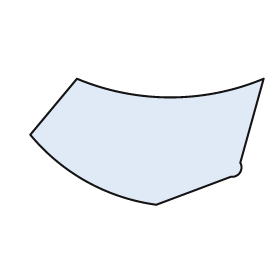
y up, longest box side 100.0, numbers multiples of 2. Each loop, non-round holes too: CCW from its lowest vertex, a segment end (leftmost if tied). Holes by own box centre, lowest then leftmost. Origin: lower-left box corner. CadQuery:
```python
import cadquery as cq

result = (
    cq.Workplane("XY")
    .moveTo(54.0, 0.0)
    .lineTo(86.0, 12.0)
    .threePointArc((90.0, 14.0), (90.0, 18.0))
    .lineTo(100.0, 54.0)
    .threePointArc((60.0, 46.0), (20.0, 54.0))
    .lineTo(0.0, 30.0)
    .threePointArc((24.0, 10.0), (54.0, 0.0))
    .close()
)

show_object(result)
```